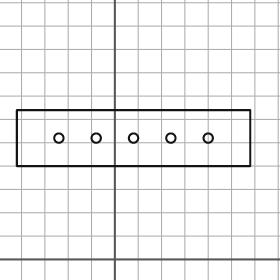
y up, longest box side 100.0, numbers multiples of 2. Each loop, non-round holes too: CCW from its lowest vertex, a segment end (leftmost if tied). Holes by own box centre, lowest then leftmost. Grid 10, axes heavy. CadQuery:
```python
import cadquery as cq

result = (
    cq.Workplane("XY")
    .moveTo(-42.0, 40.0)
    .lineTo(58.0, 40.0)
    .lineTo(58.0, 64.0)
    .lineTo(-42.0, 64.0)
    .close()
    .moveTo(-24.0, 52.0)
    .circle(2.0)
    .moveTo(-8.0, 52.0)
    .circle(2.0)
    .moveTo(8.0, 52.0)
    .circle(2.0)
    .moveTo(24.0, 52.0)
    .circle(2.0)
    .moveTo(40.0, 52.0)
    .circle(2.0)
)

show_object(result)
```